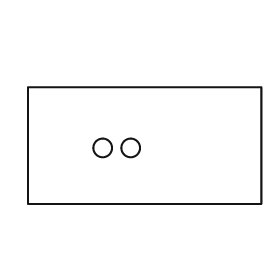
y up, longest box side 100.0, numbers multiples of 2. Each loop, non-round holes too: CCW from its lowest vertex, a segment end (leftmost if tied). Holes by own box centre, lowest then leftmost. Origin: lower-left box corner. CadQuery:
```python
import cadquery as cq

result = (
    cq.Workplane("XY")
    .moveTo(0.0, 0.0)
    .lineTo(100.0, 0.0)
    .lineTo(100.0, 50.0)
    .lineTo(0.0, 50.0)
    .close()
    .moveTo(32.0, 24.0)
    .circle(4.0)
    .moveTo(44.0, 24.0)
    .circle(4.0)
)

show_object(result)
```